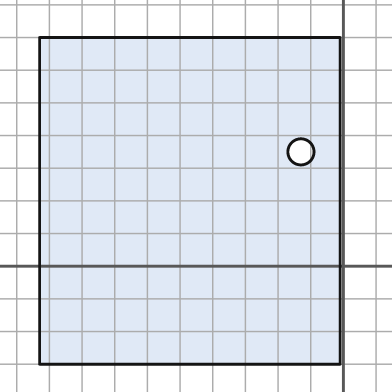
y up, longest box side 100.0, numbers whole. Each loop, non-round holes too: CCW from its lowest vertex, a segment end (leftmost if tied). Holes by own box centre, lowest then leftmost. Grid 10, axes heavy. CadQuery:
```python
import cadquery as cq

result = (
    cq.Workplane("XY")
    .moveTo(-93.0, -30.0)
    .lineTo(-1.0, -30.0)
    .lineTo(-1.0, 70.0)
    .lineTo(-93.0, 70.0)
    .close()
    .moveTo(-13.0, 35.0)
    .circle(4.0)
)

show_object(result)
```